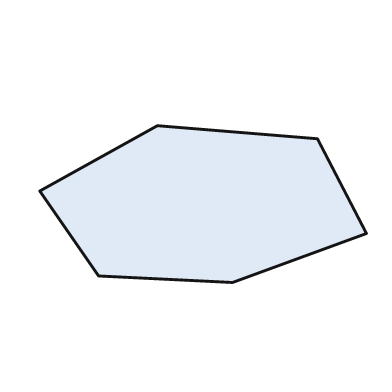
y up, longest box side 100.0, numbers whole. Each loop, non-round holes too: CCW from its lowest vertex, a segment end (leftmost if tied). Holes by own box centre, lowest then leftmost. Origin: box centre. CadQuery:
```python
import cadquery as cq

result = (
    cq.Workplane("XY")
    .moveTo(9.0, -24.0)
    .lineTo(50.0, -9.0)
    .lineTo(35.0, 20.0)
    .lineTo(-14.0, 24.0)
    .lineTo(-50.0, 4.0)
    .lineTo(-32.0, -22.0)
    .close()
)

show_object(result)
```